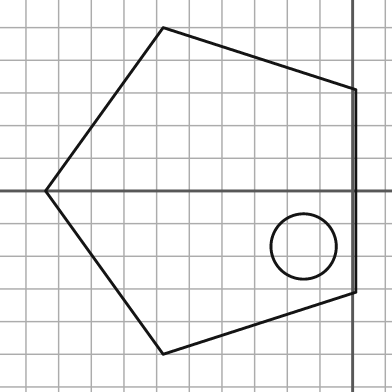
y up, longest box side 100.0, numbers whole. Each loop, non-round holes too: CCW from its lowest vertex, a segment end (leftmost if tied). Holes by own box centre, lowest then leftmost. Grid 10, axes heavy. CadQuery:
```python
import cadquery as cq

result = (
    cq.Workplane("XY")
    .moveTo(-58.0, -50.0)
    .lineTo(1.0, -31.0)
    .lineTo(1.0, 31.0)
    .lineTo(-58.0, 50.0)
    .lineTo(-94.0, 0.0)
    .close()
    .moveTo(-15.0, -17.0)
    .circle(10.0)
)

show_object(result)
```